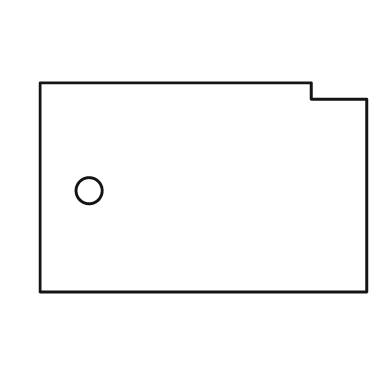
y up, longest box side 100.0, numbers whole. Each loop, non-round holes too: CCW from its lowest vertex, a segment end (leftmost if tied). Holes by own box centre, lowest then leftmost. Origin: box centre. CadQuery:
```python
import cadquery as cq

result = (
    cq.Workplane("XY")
    .moveTo(-50.0, -32.0)
    .lineTo(50.0, -32.0)
    .lineTo(50.0, 27.0)
    .lineTo(33.0, 27.0)
    .lineTo(33.0, 32.0)
    .lineTo(-50.0, 32.0)
    .close()
    .moveTo(-35.0, -1.0)
    .circle(4.0)
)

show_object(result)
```